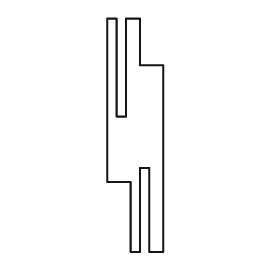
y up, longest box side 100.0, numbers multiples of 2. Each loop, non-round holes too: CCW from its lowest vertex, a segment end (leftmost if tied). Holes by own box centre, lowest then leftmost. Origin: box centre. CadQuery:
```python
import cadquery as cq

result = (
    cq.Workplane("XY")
    .moveTo(-2.0, -50.0)
    .lineTo(2.0, -50.0)
    .lineTo(2.0, -14.0)
    .lineTo(6.0, -14.0)
    .lineTo(6.0, -50.0)
    .lineTo(12.0, -50.0)
    .lineTo(12.0, 30.0)
    .lineTo(2.0, 30.0)
    .lineTo(2.0, 50.0)
    .lineTo(-4.0, 50.0)
    .lineTo(-4.0, 8.0)
    .lineTo(-8.0, 8.0)
    .lineTo(-8.0, 50.0)
    .lineTo(-12.0, 50.0)
    .lineTo(-12.0, -20.0)
    .lineTo(-2.0, -20.0)
    .close()
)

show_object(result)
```